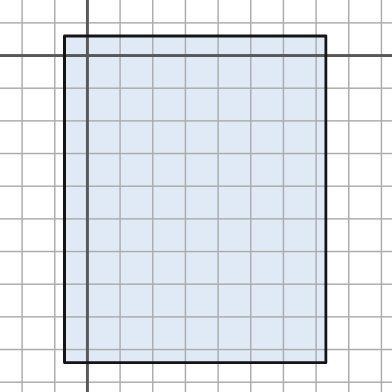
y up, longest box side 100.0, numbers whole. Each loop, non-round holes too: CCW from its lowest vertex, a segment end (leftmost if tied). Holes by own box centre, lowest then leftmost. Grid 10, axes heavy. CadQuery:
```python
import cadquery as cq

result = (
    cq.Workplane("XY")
    .moveTo(-7.0, -94.0)
    .lineTo(73.0, -94.0)
    .lineTo(73.0, 6.0)
    .lineTo(-7.0, 6.0)
    .close()
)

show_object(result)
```